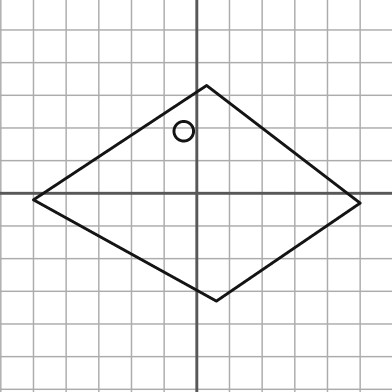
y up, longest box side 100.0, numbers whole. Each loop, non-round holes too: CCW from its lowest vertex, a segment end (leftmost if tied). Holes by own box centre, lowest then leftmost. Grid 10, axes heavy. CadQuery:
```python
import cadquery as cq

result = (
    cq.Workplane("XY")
    .moveTo(6.0, -33.0)
    .lineTo(50.0, -3.0)
    .lineTo(3.0, 33.0)
    .lineTo(-50.0, -2.0)
    .close()
    .moveTo(-4.0, 19.0)
    .circle(3.0)
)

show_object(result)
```